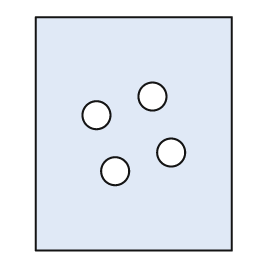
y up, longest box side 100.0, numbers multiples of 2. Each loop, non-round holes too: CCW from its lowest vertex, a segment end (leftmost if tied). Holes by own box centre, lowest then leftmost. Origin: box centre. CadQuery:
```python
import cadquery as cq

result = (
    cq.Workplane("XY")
    .moveTo(-42.0, -50.0)
    .lineTo(42.0, -50.0)
    .lineTo(42.0, 50.0)
    .lineTo(-42.0, 50.0)
    .close()
    .moveTo(-8.0, -16.0)
    .circle(6.0)
    .moveTo(16.0, -8.0)
    .circle(6.0)
    .moveTo(-16.0, 8.0)
    .circle(6.0)
    .moveTo(8.0, 16.0)
    .circle(6.0)
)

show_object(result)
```